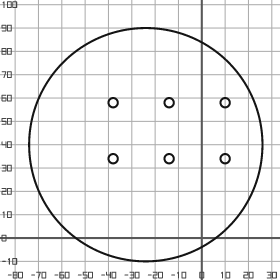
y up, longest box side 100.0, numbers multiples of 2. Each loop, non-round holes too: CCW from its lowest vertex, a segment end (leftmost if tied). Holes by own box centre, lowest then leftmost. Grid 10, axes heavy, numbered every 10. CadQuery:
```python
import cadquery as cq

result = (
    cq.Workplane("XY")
    .moveTo(-24.0, 40.0)
    .circle(50.0)
    .moveTo(-38.0, 34.0)
    .circle(2.0)
    .moveTo(-14.0, 34.0)
    .circle(2.0)
    .moveTo(10.0, 34.0)
    .circle(2.0)
    .moveTo(-38.0, 58.0)
    .circle(2.0)
    .moveTo(-14.0, 58.0)
    .circle(2.0)
    .moveTo(10.0, 58.0)
    .circle(2.0)
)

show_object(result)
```